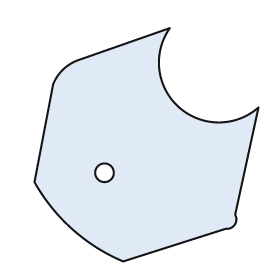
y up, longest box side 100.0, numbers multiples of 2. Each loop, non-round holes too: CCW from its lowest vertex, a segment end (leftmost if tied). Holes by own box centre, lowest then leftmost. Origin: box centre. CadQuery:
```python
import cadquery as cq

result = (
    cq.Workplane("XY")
    .moveTo(-10.0, -50.0)
    .lineTo(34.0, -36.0)
    .threePointArc((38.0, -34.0), (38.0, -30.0))
    .lineTo(48.0, 16.0)
    .threePointArc((14.0, 16.0), (10.0, 50.0))
    .lineTo(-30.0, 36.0)
    .threePointArc((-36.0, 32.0), (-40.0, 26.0))
    .lineTo(-48.0, -16.0)
    .threePointArc((-32.0, -36.0), (-10.0, -50.0))
    .close()
    .moveTo(-18.0, -12.0)
    .circle(4.0)
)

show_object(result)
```